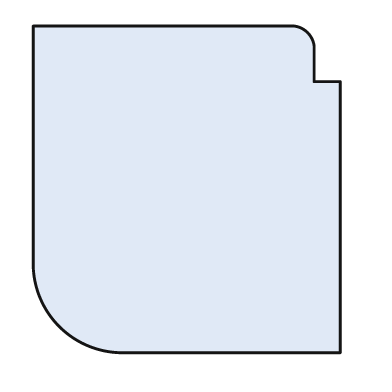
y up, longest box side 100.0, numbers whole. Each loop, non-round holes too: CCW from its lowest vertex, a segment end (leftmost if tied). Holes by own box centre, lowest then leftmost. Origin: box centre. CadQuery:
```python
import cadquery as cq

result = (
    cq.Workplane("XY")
    .moveTo(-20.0, -50.0)
    .lineTo(47.0, -50.0)
    .lineTo(47.0, 33.0)
    .lineTo(39.0, 33.0)
    .lineTo(39.0, 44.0)
    .threePointArc((37.0, 48.0), (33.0, 50.0))
    .lineTo(-47.0, 50.0)
    .lineTo(-47.0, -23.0)
    .threePointArc((-39.0, -42.0), (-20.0, -50.0))
    .close()
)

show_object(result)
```